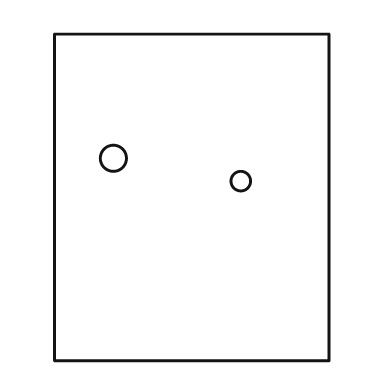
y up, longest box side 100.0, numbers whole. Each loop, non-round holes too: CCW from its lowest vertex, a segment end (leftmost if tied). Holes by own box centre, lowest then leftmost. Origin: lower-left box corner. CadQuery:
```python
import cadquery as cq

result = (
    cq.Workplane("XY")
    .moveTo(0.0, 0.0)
    .lineTo(84.0, 0.0)
    .lineTo(84.0, 100.0)
    .lineTo(0.0, 100.0)
    .close()
    .moveTo(57.0, 55.0)
    .circle(3.0)
    .moveTo(18.0, 62.0)
    .circle(4.0)
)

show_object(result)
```